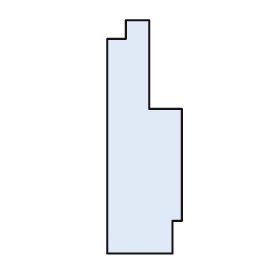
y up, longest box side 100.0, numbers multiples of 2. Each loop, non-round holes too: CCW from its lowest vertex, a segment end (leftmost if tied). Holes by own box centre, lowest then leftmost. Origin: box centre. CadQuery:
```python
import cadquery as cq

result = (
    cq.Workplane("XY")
    .moveTo(-16.0, -50.0)
    .lineTo(12.0, -50.0)
    .lineTo(12.0, -36.0)
    .lineTo(16.0, -36.0)
    .lineTo(16.0, 12.0)
    .lineTo(2.0, 12.0)
    .lineTo(2.0, 50.0)
    .lineTo(-8.0, 50.0)
    .lineTo(-8.0, 42.0)
    .lineTo(-16.0, 42.0)
    .close()
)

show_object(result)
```